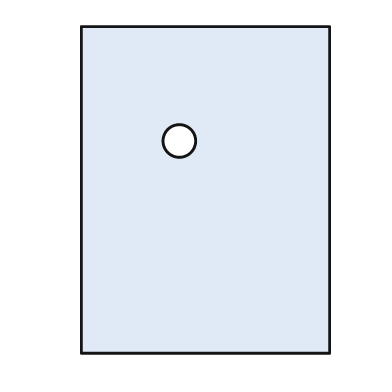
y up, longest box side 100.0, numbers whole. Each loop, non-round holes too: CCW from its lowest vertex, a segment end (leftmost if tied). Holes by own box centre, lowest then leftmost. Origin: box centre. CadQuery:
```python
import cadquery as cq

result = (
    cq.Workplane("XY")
    .moveTo(-38.0, -50.0)
    .lineTo(38.0, -50.0)
    .lineTo(38.0, 50.0)
    .lineTo(-38.0, 50.0)
    .close()
    .moveTo(-8.0, 15.0)
    .circle(5.0)
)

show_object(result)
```